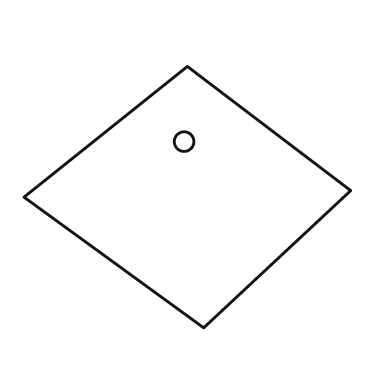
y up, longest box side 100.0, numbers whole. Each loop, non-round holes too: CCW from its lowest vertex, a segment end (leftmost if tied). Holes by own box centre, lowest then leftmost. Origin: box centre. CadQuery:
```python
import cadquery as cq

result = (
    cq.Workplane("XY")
    .moveTo(5.0, -40.0)
    .lineTo(50.0, 2.0)
    .lineTo(0.0, 40.0)
    .lineTo(-50.0, 0.0)
    .close()
    .moveTo(-1.0, 17.0)
    .circle(3.0)
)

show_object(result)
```